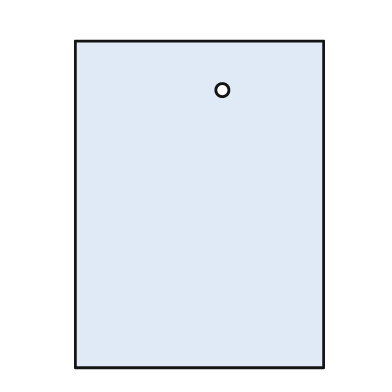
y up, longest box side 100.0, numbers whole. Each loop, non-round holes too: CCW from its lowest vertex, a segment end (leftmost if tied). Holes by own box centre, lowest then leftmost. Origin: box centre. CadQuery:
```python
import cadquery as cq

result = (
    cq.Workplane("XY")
    .moveTo(-38.0, -50.0)
    .lineTo(38.0, -50.0)
    .lineTo(38.0, 50.0)
    .lineTo(-38.0, 50.0)
    .close()
    .moveTo(7.0, 35.0)
    .circle(2.0)
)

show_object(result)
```